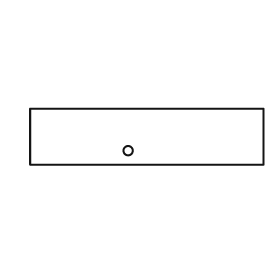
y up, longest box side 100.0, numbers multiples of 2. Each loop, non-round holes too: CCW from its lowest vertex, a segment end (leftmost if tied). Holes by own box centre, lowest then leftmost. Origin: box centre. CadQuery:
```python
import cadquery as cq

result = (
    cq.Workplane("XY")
    .moveTo(-50.0, -12.0)
    .lineTo(50.0, -12.0)
    .lineTo(50.0, 12.0)
    .lineTo(-50.0, 12.0)
    .close()
    .moveTo(-8.0, -6.0)
    .circle(2.0)
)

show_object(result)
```